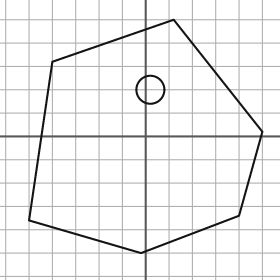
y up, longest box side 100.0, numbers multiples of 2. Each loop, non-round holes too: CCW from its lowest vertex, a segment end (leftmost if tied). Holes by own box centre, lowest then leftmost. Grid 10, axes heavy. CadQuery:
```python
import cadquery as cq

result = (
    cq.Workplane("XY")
    .moveTo(-2.0, -50.0)
    .lineTo(40.0, -34.0)
    .lineTo(50.0, 2.0)
    .lineTo(12.0, 50.0)
    .lineTo(-40.0, 32.0)
    .lineTo(-50.0, -36.0)
    .close()
    .moveTo(2.0, 20.0)
    .circle(6.0)
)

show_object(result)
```